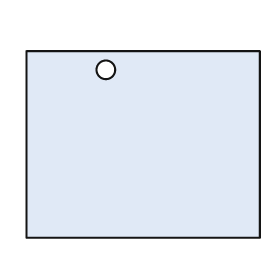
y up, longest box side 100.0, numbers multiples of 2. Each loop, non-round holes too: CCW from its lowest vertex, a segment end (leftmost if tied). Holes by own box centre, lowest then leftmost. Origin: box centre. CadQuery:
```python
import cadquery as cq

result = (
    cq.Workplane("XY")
    .moveTo(-50.0, -40.0)
    .lineTo(50.0, -40.0)
    .lineTo(50.0, 40.0)
    .lineTo(-50.0, 40.0)
    .close()
    .moveTo(-16.0, 32.0)
    .circle(4.0)
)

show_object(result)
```